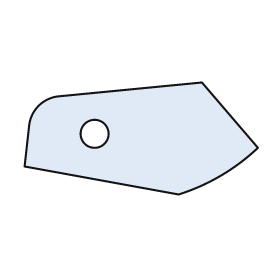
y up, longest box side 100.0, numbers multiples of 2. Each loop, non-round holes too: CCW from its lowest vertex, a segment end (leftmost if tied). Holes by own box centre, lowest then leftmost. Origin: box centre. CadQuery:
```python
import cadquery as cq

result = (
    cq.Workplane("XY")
    .moveTo(16.0, -24.0)
    .threePointArc((34.0, -16.0), (50.0, -4.0))
    .lineTo(26.0, 24.0)
    .lineTo(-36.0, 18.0)
    .threePointArc((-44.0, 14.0), (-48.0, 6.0))
    .lineTo(-50.0, -12.0)
    .close()
    .moveTo(-20.0, 2.0)
    .circle(6.0)
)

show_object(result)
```